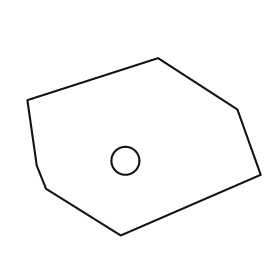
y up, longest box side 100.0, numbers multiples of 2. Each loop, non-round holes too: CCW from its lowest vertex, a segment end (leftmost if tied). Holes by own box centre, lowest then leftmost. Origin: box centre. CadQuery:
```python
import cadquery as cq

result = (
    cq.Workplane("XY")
    .moveTo(-10.0, -38.0)
    .lineTo(50.0, -12.0)
    .lineTo(40.0, 16.0)
    .lineTo(6.0, 38.0)
    .lineTo(-50.0, 20.0)
    .lineTo(-46.0, -8.0)
    .lineTo(-42.0, -18.0)
    .close()
    .moveTo(-8.0, -6.0)
    .circle(6.0)
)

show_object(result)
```